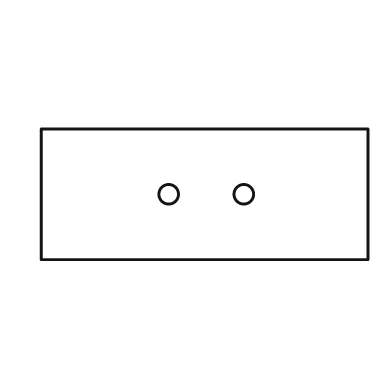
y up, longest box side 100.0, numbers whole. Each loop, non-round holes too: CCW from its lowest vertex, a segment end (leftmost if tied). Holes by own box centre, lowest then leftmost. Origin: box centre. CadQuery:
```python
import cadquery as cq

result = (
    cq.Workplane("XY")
    .moveTo(-50.0, -20.0)
    .lineTo(50.0, -20.0)
    .lineTo(50.0, 20.0)
    .lineTo(-50.0, 20.0)
    .close()
    .moveTo(-11.0, 0.0)
    .circle(3.0)
    .moveTo(12.0, 0.0)
    .circle(3.0)
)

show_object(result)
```